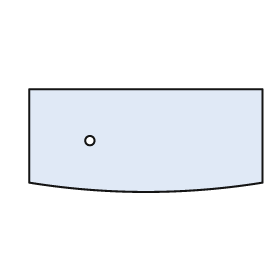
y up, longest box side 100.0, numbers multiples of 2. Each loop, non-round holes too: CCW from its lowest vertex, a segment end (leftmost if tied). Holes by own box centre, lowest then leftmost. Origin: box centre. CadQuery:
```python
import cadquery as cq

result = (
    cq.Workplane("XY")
    .moveTo(-50.0, -18.0)
    .threePointArc((0.0, -22.0), (50.0, -18.0))
    .lineTo(50.0, 22.0)
    .lineTo(-50.0, 22.0)
    .close()
    .moveTo(-24.0, 0.0)
    .circle(2.0)
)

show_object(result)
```